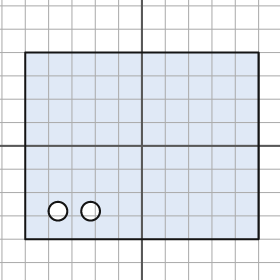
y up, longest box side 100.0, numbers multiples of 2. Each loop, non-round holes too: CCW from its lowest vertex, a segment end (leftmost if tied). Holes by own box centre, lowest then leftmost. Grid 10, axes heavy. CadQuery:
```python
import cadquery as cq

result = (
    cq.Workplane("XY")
    .moveTo(-50.0, -40.0)
    .lineTo(50.0, -40.0)
    .lineTo(50.0, 40.0)
    .lineTo(-50.0, 40.0)
    .close()
    .moveTo(-36.0, -28.0)
    .circle(4.0)
    .moveTo(-22.0, -28.0)
    .circle(4.0)
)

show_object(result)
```